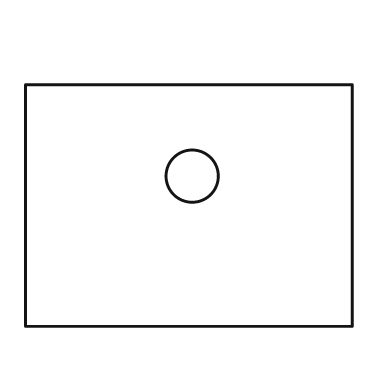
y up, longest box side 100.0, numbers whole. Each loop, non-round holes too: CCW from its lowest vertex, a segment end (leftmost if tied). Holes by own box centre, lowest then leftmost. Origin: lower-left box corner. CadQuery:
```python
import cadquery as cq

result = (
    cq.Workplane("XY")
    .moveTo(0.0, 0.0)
    .lineTo(100.0, 0.0)
    .lineTo(100.0, 74.0)
    .lineTo(0.0, 74.0)
    .close()
    .moveTo(51.0, 46.0)
    .circle(8.0)
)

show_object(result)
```